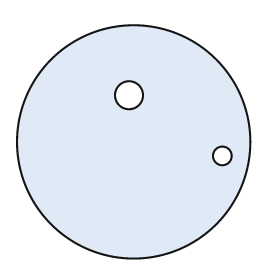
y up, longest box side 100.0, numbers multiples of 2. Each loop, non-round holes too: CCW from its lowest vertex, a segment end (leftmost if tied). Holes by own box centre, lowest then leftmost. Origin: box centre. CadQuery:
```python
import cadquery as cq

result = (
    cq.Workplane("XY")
    .moveTo(0.0, 0.0)
    .circle(50.0)
    .moveTo(38.0, -6.0)
    .circle(4.0)
    .moveTo(-2.0, 20.0)
    .circle(6.0)
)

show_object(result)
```